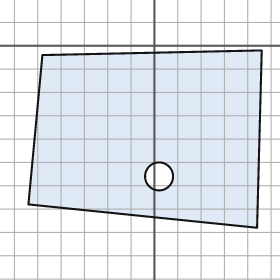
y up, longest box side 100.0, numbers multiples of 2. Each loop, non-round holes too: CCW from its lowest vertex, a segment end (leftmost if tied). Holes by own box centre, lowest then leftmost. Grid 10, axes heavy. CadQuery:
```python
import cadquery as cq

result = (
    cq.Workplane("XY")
    .moveTo(44.0, -78.0)
    .lineTo(46.0, -2.0)
    .lineTo(-48.0, -4.0)
    .lineTo(-54.0, -68.0)
    .close()
    .moveTo(2.0, -56.0)
    .circle(6.0)
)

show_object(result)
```